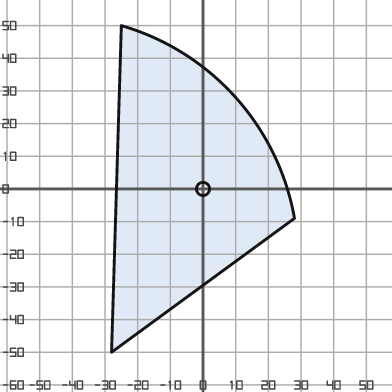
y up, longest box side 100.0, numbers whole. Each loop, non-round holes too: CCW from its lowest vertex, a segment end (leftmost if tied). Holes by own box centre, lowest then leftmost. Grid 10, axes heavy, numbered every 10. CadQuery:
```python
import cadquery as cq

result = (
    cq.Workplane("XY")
    .moveTo(-28.0, -50.0)
    .lineTo(28.0, -9.0)
    .threePointArc((10.0, 28.0), (-25.0, 50.0))
    .close()
    .moveTo(0.0, 0.0)
    .circle(2.0)
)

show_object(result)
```